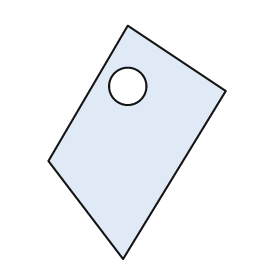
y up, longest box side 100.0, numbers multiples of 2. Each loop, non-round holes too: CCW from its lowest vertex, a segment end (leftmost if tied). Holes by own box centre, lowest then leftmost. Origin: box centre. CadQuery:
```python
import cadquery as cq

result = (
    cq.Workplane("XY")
    .moveTo(-6.0, -50.0)
    .lineTo(38.0, 22.0)
    .lineTo(-4.0, 50.0)
    .lineTo(-38.0, -8.0)
    .close()
    .moveTo(-4.0, 24.0)
    .circle(8.0)
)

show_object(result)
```